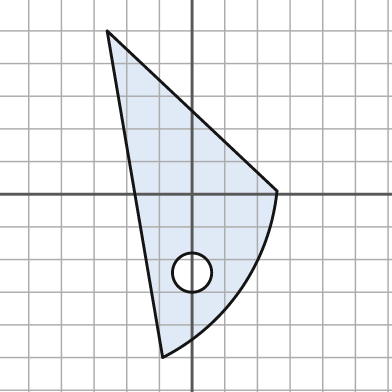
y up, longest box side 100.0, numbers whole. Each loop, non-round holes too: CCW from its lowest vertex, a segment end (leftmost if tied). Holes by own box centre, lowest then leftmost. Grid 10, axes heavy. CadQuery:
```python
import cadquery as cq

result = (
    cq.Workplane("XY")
    .moveTo(-9.0, -50.0)
    .threePointArc((15.0, -29.0), (26.0, 1.0))
    .lineTo(-26.0, 50.0)
    .close()
    .moveTo(0.0, -24.0)
    .circle(6.0)
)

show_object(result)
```